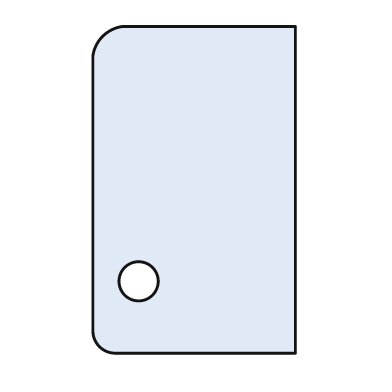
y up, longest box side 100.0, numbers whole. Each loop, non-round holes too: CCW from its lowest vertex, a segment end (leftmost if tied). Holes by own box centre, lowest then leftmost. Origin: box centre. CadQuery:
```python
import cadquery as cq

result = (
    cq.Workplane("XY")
    .moveTo(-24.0, -50.0)
    .lineTo(31.0, -50.0)
    .lineTo(31.0, 50.0)
    .lineTo(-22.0, 50.0)
    .threePointArc((-28.0, 47.0), (-31.0, 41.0))
    .lineTo(-31.0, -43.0)
    .threePointArc((-29.0, -48.0), (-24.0, -50.0))
    .close()
    .moveTo(-17.0, -28.0)
    .circle(6.0)
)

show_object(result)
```